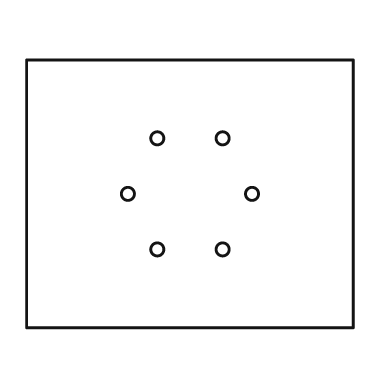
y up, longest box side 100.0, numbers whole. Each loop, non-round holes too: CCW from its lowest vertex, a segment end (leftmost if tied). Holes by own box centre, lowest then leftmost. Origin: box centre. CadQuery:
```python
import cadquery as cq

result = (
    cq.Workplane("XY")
    .moveTo(-50.0, -41.0)
    .lineTo(50.0, -41.0)
    .lineTo(50.0, 41.0)
    .lineTo(-50.0, 41.0)
    .close()
    .moveTo(-10.0, -17.0)
    .circle(2.0)
    .moveTo(10.0, -17.0)
    .circle(2.0)
    .moveTo(-19.0, 0.0)
    .circle(2.0)
    .moveTo(19.0, 0.0)
    .circle(2.0)
    .moveTo(-10.0, 17.0)
    .circle(2.0)
    .moveTo(10.0, 17.0)
    .circle(2.0)
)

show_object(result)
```